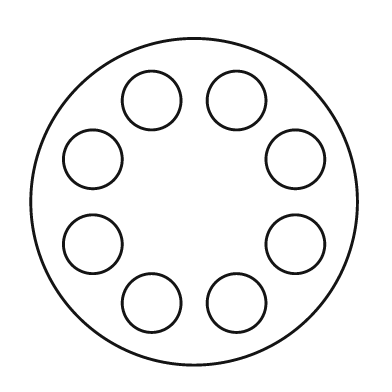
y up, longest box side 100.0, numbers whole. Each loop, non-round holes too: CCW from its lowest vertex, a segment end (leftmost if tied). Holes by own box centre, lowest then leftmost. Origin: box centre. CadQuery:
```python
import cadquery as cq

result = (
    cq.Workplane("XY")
    .moveTo(0.0, 0.0)
    .circle(50.0)
    .moveTo(-13.0, -31.0)
    .circle(9.0)
    .moveTo(13.0, -31.0)
    .circle(9.0)
    .moveTo(-31.0, -13.0)
    .circle(9.0)
    .moveTo(31.0, -13.0)
    .circle(9.0)
    .moveTo(-31.0, 13.0)
    .circle(9.0)
    .moveTo(31.0, 13.0)
    .circle(9.0)
    .moveTo(-13.0, 31.0)
    .circle(9.0)
    .moveTo(13.0, 31.0)
    .circle(9.0)
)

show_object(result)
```